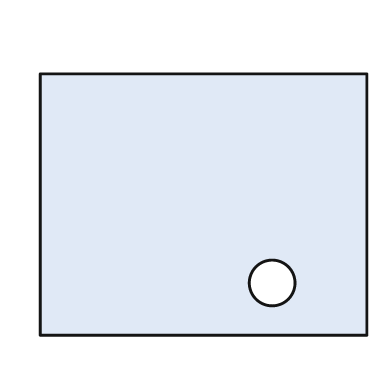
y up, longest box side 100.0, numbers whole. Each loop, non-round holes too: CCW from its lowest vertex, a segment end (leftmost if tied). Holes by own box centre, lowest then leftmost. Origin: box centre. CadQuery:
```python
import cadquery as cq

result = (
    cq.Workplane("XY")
    .moveTo(-50.0, -40.0)
    .lineTo(50.0, -40.0)
    .lineTo(50.0, 40.0)
    .lineTo(-50.0, 40.0)
    .close()
    .moveTo(21.0, -24.0)
    .circle(7.0)
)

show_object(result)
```